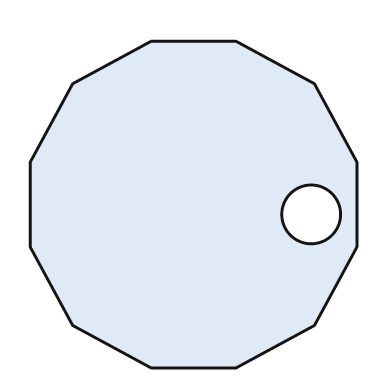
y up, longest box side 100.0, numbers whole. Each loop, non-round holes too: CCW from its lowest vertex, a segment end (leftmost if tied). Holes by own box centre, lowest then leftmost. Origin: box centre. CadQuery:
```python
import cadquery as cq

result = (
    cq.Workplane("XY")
    .moveTo(-13.0, -50.0)
    .lineTo(13.0, -50.0)
    .lineTo(37.0, -37.0)
    .lineTo(50.0, -13.0)
    .lineTo(50.0, 13.0)
    .lineTo(37.0, 37.0)
    .lineTo(13.0, 50.0)
    .lineTo(-13.0, 50.0)
    .lineTo(-37.0, 37.0)
    .lineTo(-50.0, 13.0)
    .lineTo(-50.0, -13.0)
    .lineTo(-37.0, -37.0)
    .close()
    .moveTo(36.0, -3.0)
    .circle(9.0)
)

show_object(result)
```